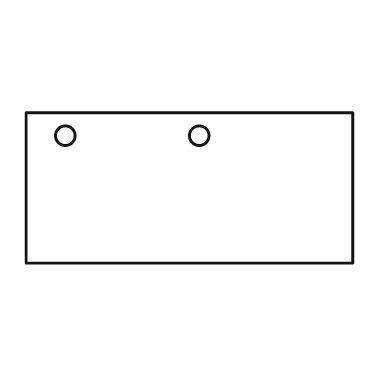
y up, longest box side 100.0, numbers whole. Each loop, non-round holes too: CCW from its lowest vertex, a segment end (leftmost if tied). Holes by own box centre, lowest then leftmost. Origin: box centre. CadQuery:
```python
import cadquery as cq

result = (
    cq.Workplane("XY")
    .moveTo(-50.0, -23.0)
    .lineTo(50.0, -23.0)
    .lineTo(50.0, 23.0)
    .lineTo(-50.0, 23.0)
    .close()
    .moveTo(-38.0, 16.0)
    .circle(3.0)
    .moveTo(3.0, 16.0)
    .circle(3.0)
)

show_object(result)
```